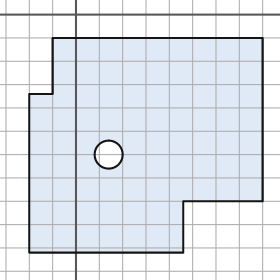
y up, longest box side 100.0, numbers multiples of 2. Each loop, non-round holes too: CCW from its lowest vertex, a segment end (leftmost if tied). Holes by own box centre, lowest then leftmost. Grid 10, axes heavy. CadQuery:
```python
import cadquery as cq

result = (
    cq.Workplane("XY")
    .moveTo(-20.0, -102.0)
    .lineTo(46.0, -102.0)
    .lineTo(46.0, -80.0)
    .lineTo(80.0, -80.0)
    .lineTo(80.0, -10.0)
    .lineTo(-10.0, -10.0)
    .lineTo(-10.0, -34.0)
    .lineTo(-20.0, -34.0)
    .close()
    .moveTo(14.0, -60.0)
    .circle(6.0)
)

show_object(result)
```